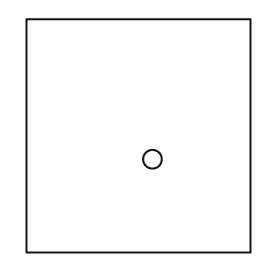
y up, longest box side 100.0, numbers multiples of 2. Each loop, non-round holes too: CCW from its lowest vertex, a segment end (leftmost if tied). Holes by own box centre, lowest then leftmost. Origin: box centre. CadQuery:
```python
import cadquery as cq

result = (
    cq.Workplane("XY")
    .moveTo(-48.0, -50.0)
    .lineTo(48.0, -50.0)
    .lineTo(48.0, 50.0)
    .lineTo(-48.0, 50.0)
    .close()
    .moveTo(6.0, -10.0)
    .circle(4.0)
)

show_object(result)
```